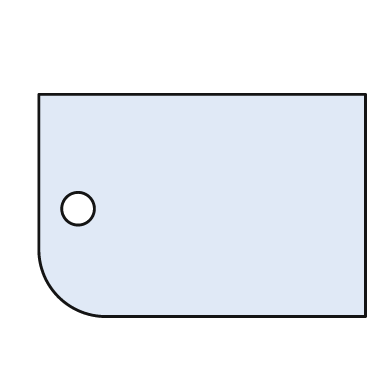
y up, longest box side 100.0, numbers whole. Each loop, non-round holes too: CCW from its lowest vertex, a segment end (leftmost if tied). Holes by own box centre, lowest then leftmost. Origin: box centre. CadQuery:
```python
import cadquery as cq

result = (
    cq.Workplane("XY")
    .moveTo(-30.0, -34.0)
    .lineTo(50.0, -34.0)
    .lineTo(50.0, 34.0)
    .lineTo(-50.0, 34.0)
    .lineTo(-50.0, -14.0)
    .threePointArc((-44.0, -28.0), (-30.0, -34.0))
    .close()
    .moveTo(-38.0, -1.0)
    .circle(5.0)
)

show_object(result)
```